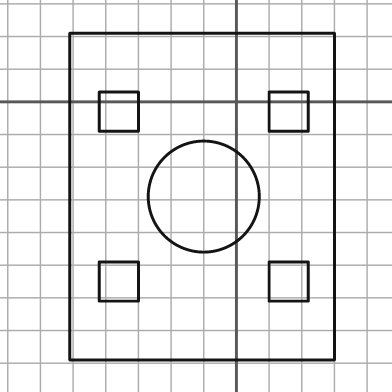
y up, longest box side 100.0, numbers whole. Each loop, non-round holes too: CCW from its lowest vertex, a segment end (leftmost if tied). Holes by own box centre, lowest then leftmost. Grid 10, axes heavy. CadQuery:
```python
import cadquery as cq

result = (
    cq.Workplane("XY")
    .moveTo(-51.0, -79.0)
    .lineTo(30.0, -79.0)
    .lineTo(30.0, 21.0)
    .lineTo(-51.0, 21.0)
    .close()
    .moveTo(-42.0, -61.0)
    .lineTo(-30.0, -61.0)
    .lineTo(-30.0, -49.0)
    .lineTo(-42.0, -49.0)
    .close()
    .moveTo(10.0, -61.0)
    .lineTo(22.0, -61.0)
    .lineTo(22.0, -49.0)
    .lineTo(10.0, -49.0)
    .close()
    .moveTo(-10.0, -29.0)
    .circle(17.0)
    .moveTo(-42.0, -9.0)
    .lineTo(-30.0, -9.0)
    .lineTo(-30.0, 3.0)
    .lineTo(-42.0, 3.0)
    .close()
    .moveTo(10.0, -9.0)
    .lineTo(22.0, -9.0)
    .lineTo(22.0, 3.0)
    .lineTo(10.0, 3.0)
    .close()
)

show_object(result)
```